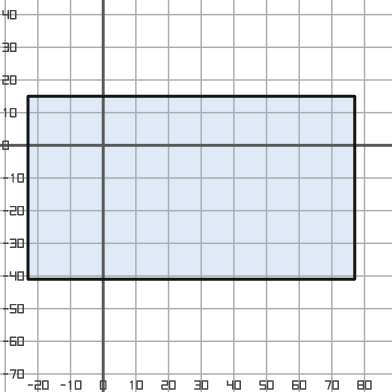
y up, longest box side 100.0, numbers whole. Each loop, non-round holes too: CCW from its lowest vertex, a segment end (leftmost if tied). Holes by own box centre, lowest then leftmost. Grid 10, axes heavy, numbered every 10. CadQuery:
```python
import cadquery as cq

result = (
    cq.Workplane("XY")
    .moveTo(-23.0, -41.0)
    .lineTo(77.0, -41.0)
    .lineTo(77.0, 15.0)
    .lineTo(-23.0, 15.0)
    .close()
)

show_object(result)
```